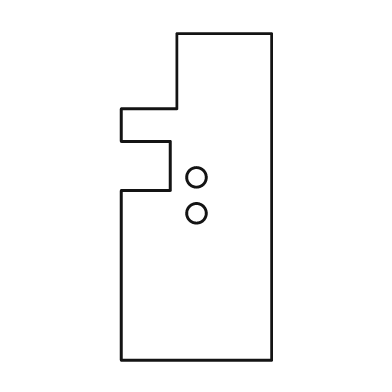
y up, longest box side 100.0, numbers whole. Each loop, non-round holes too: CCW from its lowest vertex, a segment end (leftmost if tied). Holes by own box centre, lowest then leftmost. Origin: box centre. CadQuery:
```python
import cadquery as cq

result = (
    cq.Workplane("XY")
    .moveTo(-23.0, -50.0)
    .lineTo(23.0, -50.0)
    .lineTo(23.0, 50.0)
    .lineTo(-6.0, 50.0)
    .lineTo(-6.0, 27.0)
    .lineTo(-23.0, 27.0)
    .lineTo(-23.0, 17.0)
    .lineTo(-8.0, 17.0)
    .lineTo(-8.0, 2.0)
    .lineTo(-23.0, 2.0)
    .close()
    .moveTo(0.0, -5.0)
    .circle(3.0)
    .moveTo(0.0, 6.0)
    .circle(3.0)
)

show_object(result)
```